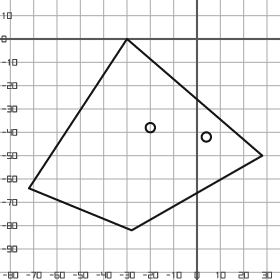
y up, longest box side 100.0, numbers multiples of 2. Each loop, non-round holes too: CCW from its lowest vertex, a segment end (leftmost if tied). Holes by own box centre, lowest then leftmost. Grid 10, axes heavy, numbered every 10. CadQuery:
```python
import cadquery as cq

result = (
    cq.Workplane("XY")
    .moveTo(-28.0, -82.0)
    .lineTo(28.0, -50.0)
    .lineTo(-30.0, 0.0)
    .lineTo(-72.0, -64.0)
    .close()
    .moveTo(4.0, -42.0)
    .circle(2.0)
    .moveTo(-20.0, -38.0)
    .circle(2.0)
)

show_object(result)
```